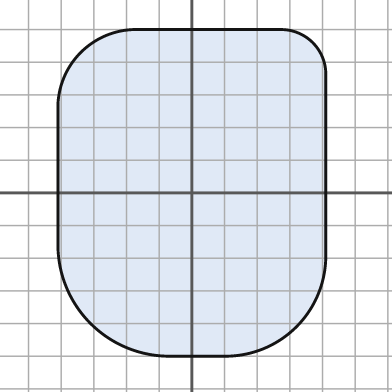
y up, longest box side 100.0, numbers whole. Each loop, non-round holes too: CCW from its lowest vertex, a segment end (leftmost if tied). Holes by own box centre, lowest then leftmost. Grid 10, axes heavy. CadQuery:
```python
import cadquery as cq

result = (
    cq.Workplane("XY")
    .moveTo(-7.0, -50.0)
    .lineTo(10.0, -50.0)
    .threePointArc((32.0, -41.0), (41.0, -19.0))
    .lineTo(41.0, 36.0)
    .threePointArc((37.0, 46.0), (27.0, 50.0))
    .lineTo(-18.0, 50.0)
    .threePointArc((-34.0, 43.0), (-41.0, 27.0))
    .lineTo(-41.0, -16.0)
    .threePointArc((-31.0, -40.0), (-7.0, -50.0))
    .close()
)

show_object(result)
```